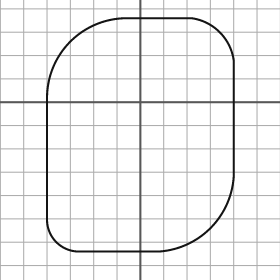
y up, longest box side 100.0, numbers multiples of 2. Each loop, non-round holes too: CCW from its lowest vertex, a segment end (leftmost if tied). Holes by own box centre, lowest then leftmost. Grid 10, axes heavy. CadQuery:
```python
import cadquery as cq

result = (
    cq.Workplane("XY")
    .moveTo(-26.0, -64.0)
    .lineTo(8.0, -64.0)
    .threePointArc((30.0, -54.0), (40.0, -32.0))
    .lineTo(40.0, 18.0)
    .threePointArc((34.0, 30.0), (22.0, 36.0))
    .lineTo(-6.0, 36.0)
    .threePointArc((-30.0, 26.0), (-40.0, 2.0))
    .lineTo(-40.0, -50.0)
    .threePointArc((-36.0, -60.0), (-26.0, -64.0))
    .close()
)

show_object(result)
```